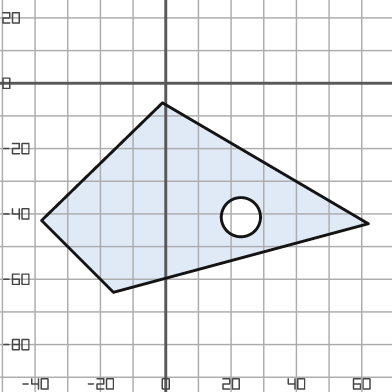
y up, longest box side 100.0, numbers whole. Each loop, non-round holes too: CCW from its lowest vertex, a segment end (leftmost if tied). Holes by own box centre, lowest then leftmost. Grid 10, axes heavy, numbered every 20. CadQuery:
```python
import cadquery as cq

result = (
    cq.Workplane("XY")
    .moveTo(-16.0, -64.0)
    .lineTo(62.0, -43.0)
    .lineTo(-1.0, -6.0)
    .lineTo(-38.0, -42.0)
    .close()
    .moveTo(23.0, -41.0)
    .circle(6.0)
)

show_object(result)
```